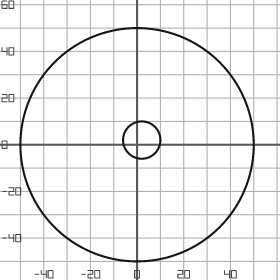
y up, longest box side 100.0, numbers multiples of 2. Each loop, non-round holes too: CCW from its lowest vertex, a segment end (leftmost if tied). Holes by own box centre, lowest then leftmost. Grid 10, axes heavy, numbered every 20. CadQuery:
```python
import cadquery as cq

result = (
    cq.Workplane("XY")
    .moveTo(0.0, 0.0)
    .circle(50.0)
    .moveTo(2.0, 2.0)
    .circle(8.0)
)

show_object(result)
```